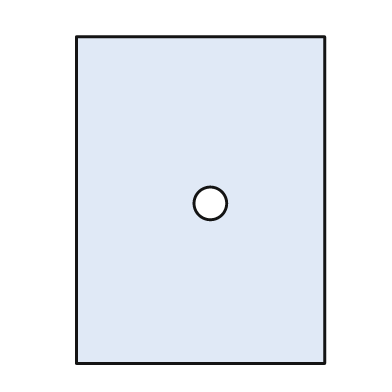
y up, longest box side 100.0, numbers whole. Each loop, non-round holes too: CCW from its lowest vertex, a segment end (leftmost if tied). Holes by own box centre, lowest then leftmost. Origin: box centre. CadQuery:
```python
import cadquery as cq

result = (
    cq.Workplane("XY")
    .moveTo(-38.0, -50.0)
    .lineTo(38.0, -50.0)
    .lineTo(38.0, 50.0)
    .lineTo(-38.0, 50.0)
    .close()
    .moveTo(3.0, -1.0)
    .circle(5.0)
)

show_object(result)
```